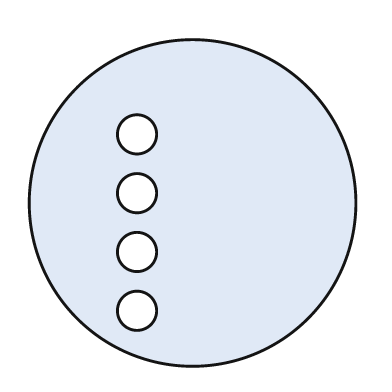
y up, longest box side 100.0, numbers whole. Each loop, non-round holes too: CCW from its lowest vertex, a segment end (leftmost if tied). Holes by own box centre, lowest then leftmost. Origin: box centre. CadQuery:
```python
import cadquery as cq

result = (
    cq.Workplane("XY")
    .moveTo(0.0, 0.0)
    .circle(50.0)
    .moveTo(-17.0, -33.0)
    .circle(6.0)
    .moveTo(-17.0, -15.0)
    .circle(6.0)
    .moveTo(-17.0, 3.0)
    .circle(6.0)
    .moveTo(-17.0, 21.0)
    .circle(6.0)
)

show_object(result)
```